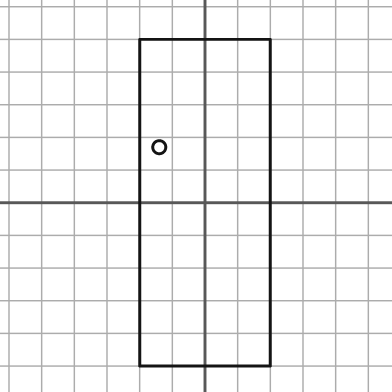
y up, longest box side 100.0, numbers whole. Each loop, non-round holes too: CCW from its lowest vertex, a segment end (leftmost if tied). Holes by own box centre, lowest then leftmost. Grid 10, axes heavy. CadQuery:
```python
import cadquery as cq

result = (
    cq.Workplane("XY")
    .moveTo(-20.0, -50.0)
    .lineTo(20.0, -50.0)
    .lineTo(20.0, 50.0)
    .lineTo(-20.0, 50.0)
    .close()
    .moveTo(-14.0, 17.0)
    .circle(2.0)
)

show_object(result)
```